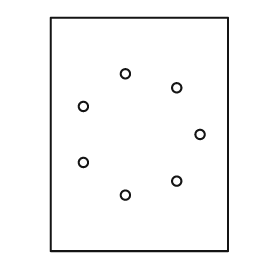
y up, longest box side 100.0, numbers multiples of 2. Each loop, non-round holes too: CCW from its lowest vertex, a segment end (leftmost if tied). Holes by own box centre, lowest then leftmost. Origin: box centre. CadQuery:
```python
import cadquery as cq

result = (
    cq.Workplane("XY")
    .moveTo(-38.0, -50.0)
    .lineTo(38.0, -50.0)
    .lineTo(38.0, 50.0)
    .lineTo(-38.0, 50.0)
    .close()
    .moveTo(-6.0, -26.0)
    .circle(2.0)
    .moveTo(16.0, -20.0)
    .circle(2.0)
    .moveTo(-24.0, -12.0)
    .circle(2.0)
    .moveTo(26.0, 0.0)
    .circle(2.0)
    .moveTo(-24.0, 12.0)
    .circle(2.0)
    .moveTo(16.0, 20.0)
    .circle(2.0)
    .moveTo(-6.0, 26.0)
    .circle(2.0)
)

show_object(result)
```